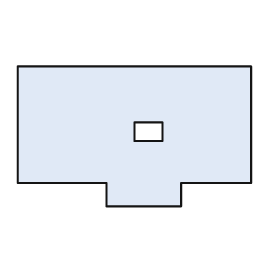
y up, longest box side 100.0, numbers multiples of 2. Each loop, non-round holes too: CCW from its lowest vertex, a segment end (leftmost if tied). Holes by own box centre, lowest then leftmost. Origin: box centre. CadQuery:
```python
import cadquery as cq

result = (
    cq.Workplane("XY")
    .moveTo(-12.0, -30.0)
    .lineTo(20.0, -30.0)
    .lineTo(20.0, -20.0)
    .lineTo(50.0, -20.0)
    .lineTo(50.0, 30.0)
    .lineTo(-50.0, 30.0)
    .lineTo(-50.0, -20.0)
    .lineTo(-12.0, -20.0)
    .close()
    .moveTo(0.0, -2.0)
    .lineTo(12.0, -2.0)
    .lineTo(12.0, 6.0)
    .lineTo(0.0, 6.0)
    .close()
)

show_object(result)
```